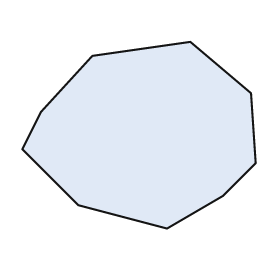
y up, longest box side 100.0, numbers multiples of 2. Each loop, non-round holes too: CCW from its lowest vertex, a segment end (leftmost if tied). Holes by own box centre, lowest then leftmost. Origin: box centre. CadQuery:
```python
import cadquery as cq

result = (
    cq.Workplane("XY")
    .moveTo(12.0, -40.0)
    .lineTo(36.0, -26.0)
    .lineTo(50.0, -12.0)
    .lineTo(48.0, 18.0)
    .lineTo(22.0, 40.0)
    .lineTo(-20.0, 34.0)
    .lineTo(-42.0, 10.0)
    .lineTo(-50.0, -6.0)
    .lineTo(-26.0, -30.0)
    .close()
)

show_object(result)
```